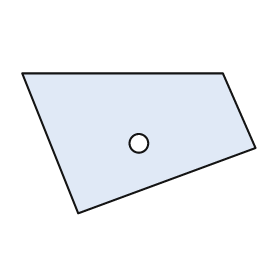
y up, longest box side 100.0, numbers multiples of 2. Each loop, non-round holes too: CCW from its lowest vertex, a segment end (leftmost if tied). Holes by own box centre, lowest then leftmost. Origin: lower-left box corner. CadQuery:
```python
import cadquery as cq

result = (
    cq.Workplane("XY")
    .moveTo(24.0, 0.0)
    .lineTo(100.0, 28.0)
    .lineTo(86.0, 60.0)
    .lineTo(0.0, 60.0)
    .close()
    .moveTo(50.0, 30.0)
    .circle(4.0)
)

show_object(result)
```